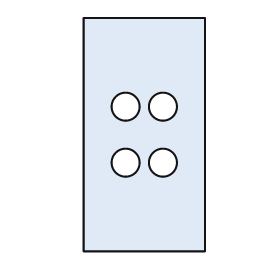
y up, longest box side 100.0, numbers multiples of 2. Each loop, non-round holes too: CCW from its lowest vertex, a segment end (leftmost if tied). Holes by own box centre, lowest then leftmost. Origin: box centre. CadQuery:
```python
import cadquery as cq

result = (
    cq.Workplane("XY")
    .moveTo(-26.0, -50.0)
    .lineTo(26.0, -50.0)
    .lineTo(26.0, 50.0)
    .lineTo(-26.0, 50.0)
    .close()
    .moveTo(-8.0, -12.0)
    .circle(6.0)
    .moveTo(8.0, -12.0)
    .circle(6.0)
    .moveTo(-8.0, 12.0)
    .circle(6.0)
    .moveTo(8.0, 12.0)
    .circle(6.0)
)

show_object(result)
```